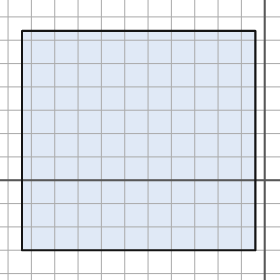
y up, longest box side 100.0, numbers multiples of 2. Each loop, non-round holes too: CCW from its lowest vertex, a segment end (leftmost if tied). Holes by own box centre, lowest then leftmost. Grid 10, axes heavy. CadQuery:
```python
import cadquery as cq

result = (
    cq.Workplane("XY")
    .moveTo(-104.0, -30.0)
    .lineTo(-4.0, -30.0)
    .lineTo(-4.0, 64.0)
    .lineTo(-104.0, 64.0)
    .close()
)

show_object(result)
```